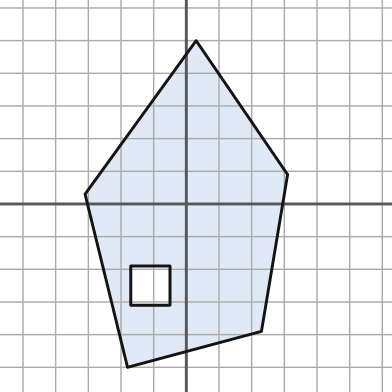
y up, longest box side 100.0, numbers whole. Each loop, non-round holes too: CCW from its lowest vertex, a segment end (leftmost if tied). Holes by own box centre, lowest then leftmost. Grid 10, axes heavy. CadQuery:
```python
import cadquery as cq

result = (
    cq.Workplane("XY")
    .moveTo(-18.0, -50.0)
    .lineTo(23.0, -39.0)
    .lineTo(31.0, 9.0)
    .lineTo(3.0, 50.0)
    .lineTo(-31.0, 3.0)
    .close()
    .moveTo(-17.0, -31.0)
    .lineTo(-5.0, -31.0)
    .lineTo(-5.0, -19.0)
    .lineTo(-17.0, -19.0)
    .close()
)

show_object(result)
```